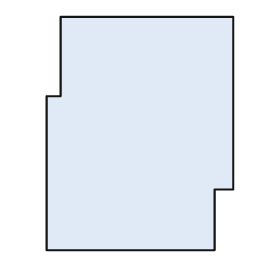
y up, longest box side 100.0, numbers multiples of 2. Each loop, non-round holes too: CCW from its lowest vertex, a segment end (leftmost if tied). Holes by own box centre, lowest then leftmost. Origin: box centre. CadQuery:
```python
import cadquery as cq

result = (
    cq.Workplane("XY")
    .moveTo(-40.0, -50.0)
    .lineTo(32.0, -50.0)
    .lineTo(32.0, -24.0)
    .lineTo(40.0, -24.0)
    .lineTo(40.0, 50.0)
    .lineTo(-34.0, 50.0)
    .lineTo(-34.0, 16.0)
    .lineTo(-40.0, 16.0)
    .close()
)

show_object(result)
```